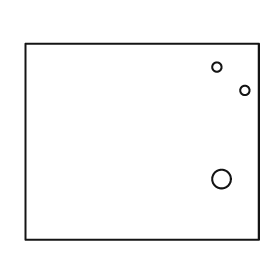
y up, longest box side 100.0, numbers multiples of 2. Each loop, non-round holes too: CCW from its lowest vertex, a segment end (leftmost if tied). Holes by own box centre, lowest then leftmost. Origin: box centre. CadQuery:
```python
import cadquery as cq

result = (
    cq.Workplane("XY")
    .moveTo(-50.0, -42.0)
    .lineTo(50.0, -42.0)
    .lineTo(50.0, 42.0)
    .lineTo(-50.0, 42.0)
    .close()
    .moveTo(34.0, -16.0)
    .circle(4.0)
    .moveTo(44.0, 22.0)
    .circle(2.0)
    .moveTo(32.0, 32.0)
    .circle(2.0)
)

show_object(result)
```